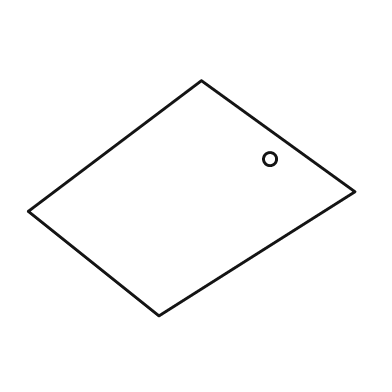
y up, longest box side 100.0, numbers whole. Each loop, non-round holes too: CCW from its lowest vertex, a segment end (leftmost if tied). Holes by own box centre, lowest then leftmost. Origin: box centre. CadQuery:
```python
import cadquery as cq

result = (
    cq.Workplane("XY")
    .moveTo(-10.0, -36.0)
    .lineTo(50.0, 2.0)
    .lineTo(3.0, 36.0)
    .lineTo(-50.0, -4.0)
    .close()
    .moveTo(24.0, 12.0)
    .circle(2.0)
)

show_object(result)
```